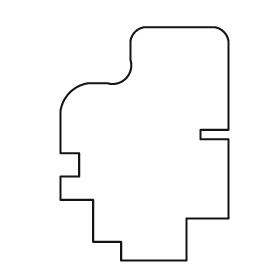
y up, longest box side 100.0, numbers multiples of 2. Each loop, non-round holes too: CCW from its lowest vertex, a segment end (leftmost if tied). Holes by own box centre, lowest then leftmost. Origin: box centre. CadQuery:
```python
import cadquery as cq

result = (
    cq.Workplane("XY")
    .moveTo(-10.0, -50.0)
    .lineTo(18.0, -50.0)
    .lineTo(18.0, -32.0)
    .lineTo(36.0, -32.0)
    .lineTo(36.0, 2.0)
    .lineTo(24.0, 2.0)
    .lineTo(24.0, 6.0)
    .lineTo(36.0, 6.0)
    .lineTo(36.0, 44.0)
    .threePointArc((34.0, 48.0), (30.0, 50.0))
    .lineTo(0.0, 50.0)
    .threePointArc((-4.0, 48.0), (-6.0, 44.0))
    .lineTo(-6.0, 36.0)
    .threePointArc((-8.0, 28.0), (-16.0, 26.0))
    .lineTo(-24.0, 26.0)
    .threePointArc((-32.0, 22.0), (-36.0, 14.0))
    .lineTo(-36.0, -4.0)
    .lineTo(-28.0, -4.0)
    .lineTo(-28.0, -14.0)
    .lineTo(-36.0, -14.0)
    .lineTo(-36.0, -24.0)
    .lineTo(-22.0, -24.0)
    .lineTo(-22.0, -42.0)
    .lineTo(-10.0, -42.0)
    .close()
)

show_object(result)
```